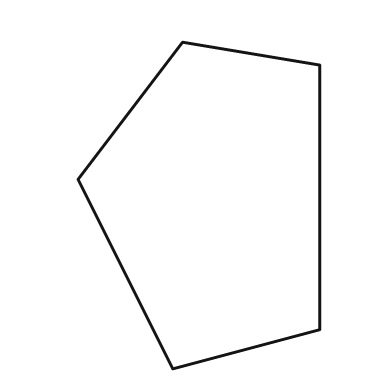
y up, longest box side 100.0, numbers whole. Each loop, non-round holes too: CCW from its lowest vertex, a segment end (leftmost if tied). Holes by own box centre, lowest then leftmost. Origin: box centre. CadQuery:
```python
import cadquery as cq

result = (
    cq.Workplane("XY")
    .moveTo(-8.0, -50.0)
    .lineTo(37.0, -38.0)
    .lineTo(37.0, 43.0)
    .lineTo(-5.0, 50.0)
    .lineTo(-37.0, 8.0)
    .close()
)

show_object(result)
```